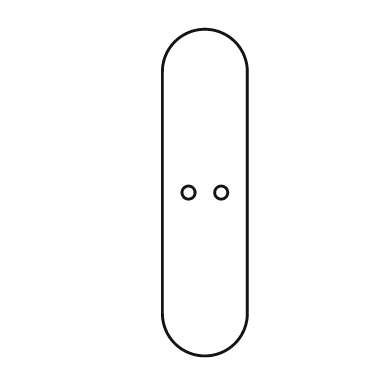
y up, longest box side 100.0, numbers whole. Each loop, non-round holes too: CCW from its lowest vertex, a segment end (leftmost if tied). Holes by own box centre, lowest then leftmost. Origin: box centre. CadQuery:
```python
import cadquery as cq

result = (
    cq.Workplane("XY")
    .moveTo(-13.0, -37.0)
    .threePointArc((0.0, -50.0), (13.0, -37.0))
    .lineTo(13.0, 37.0)
    .threePointArc((0.0, 50.0), (-13.0, 37.0))
    .close()
    .moveTo(-5.0, 0.0)
    .circle(2.0)
    .moveTo(5.0, 0.0)
    .circle(2.0)
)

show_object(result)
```